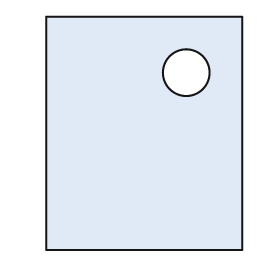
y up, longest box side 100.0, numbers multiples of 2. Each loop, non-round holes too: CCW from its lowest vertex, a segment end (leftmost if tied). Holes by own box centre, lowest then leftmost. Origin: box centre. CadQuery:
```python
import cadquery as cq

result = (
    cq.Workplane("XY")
    .moveTo(-42.0, -50.0)
    .lineTo(42.0, -50.0)
    .lineTo(42.0, 50.0)
    .lineTo(-42.0, 50.0)
    .close()
    .moveTo(18.0, 26.0)
    .circle(10.0)
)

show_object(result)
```